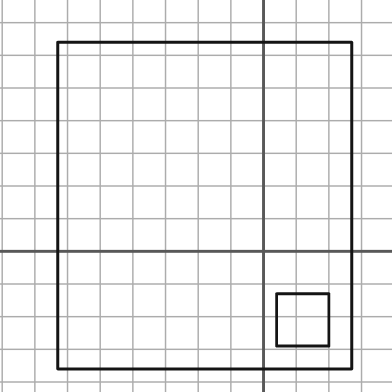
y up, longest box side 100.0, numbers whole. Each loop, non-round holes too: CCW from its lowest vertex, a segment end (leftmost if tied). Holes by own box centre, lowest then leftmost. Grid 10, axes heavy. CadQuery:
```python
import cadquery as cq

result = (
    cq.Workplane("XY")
    .moveTo(-63.0, -36.0)
    .lineTo(27.0, -36.0)
    .lineTo(27.0, 64.0)
    .lineTo(-63.0, 64.0)
    .close()
    .moveTo(4.0, -29.0)
    .lineTo(20.0, -29.0)
    .lineTo(20.0, -13.0)
    .lineTo(4.0, -13.0)
    .close()
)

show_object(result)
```